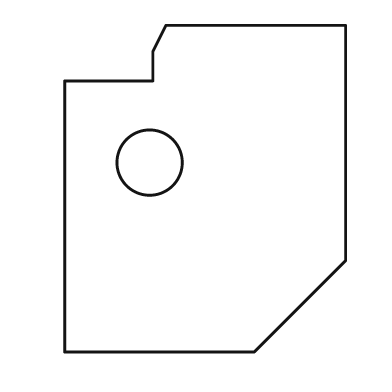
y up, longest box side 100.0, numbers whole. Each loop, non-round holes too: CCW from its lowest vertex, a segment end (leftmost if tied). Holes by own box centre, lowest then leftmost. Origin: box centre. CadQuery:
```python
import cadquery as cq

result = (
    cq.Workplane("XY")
    .moveTo(-43.0, -50.0)
    .lineTo(15.0, -50.0)
    .lineTo(43.0, -22.0)
    .lineTo(43.0, 50.0)
    .lineTo(-12.0, 50.0)
    .lineTo(-16.0, 42.0)
    .lineTo(-16.0, 33.0)
    .lineTo(-43.0, 33.0)
    .close()
    .moveTo(-17.0, 8.0)
    .circle(10.0)
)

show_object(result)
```